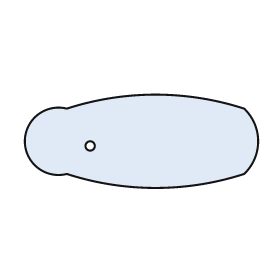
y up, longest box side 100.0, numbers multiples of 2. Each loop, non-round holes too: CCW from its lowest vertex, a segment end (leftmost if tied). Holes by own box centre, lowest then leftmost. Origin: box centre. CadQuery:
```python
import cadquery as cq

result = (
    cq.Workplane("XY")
    .moveTo(-32.0, -14.0)
    .threePointArc((6.0, -20.0), (44.0, -14.0))
    .threePointArc((50.0, 0.0), (44.0, 14.0))
    .threePointArc((6.0, 20.0), (-32.0, 14.0))
    .threePointArc((-50.0, 0.0), (-32.0, -14.0))
    .close()
    .moveTo(-22.0, -2.0)
    .circle(2.0)
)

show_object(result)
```